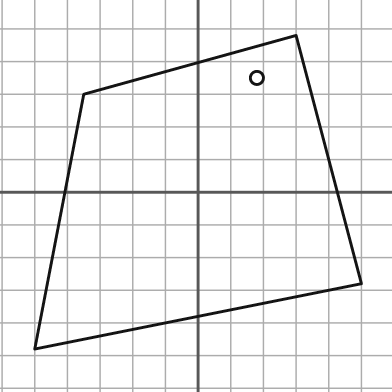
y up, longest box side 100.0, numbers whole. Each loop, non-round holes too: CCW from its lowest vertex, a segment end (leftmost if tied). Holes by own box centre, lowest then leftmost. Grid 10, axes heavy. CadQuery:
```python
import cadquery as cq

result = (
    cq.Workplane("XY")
    .moveTo(-50.0, -48.0)
    .lineTo(50.0, -28.0)
    .lineTo(30.0, 48.0)
    .lineTo(-35.0, 30.0)
    .close()
    .moveTo(18.0, 35.0)
    .circle(2.0)
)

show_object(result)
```